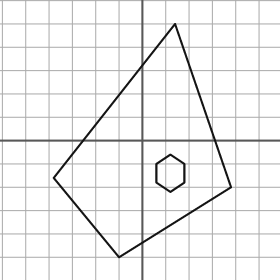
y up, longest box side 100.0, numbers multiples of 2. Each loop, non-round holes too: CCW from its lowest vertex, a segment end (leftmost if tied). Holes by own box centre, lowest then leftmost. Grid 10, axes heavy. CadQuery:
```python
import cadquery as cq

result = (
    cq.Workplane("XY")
    .moveTo(-10.0, -50.0)
    .lineTo(38.0, -20.0)
    .lineTo(14.0, 50.0)
    .lineTo(-38.0, -16.0)
    .close()
    .moveTo(12.0, -22.0)
    .lineTo(18.0, -18.0)
    .lineTo(18.0, -10.0)
    .lineTo(12.0, -6.0)
    .lineTo(6.0, -10.0)
    .lineTo(6.0, -18.0)
    .close()
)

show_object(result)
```